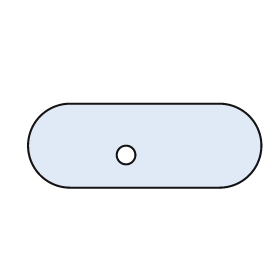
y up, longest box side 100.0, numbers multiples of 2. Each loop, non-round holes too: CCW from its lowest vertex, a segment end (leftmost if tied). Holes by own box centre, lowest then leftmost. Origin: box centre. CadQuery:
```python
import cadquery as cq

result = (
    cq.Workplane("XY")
    .moveTo(-32.0, -18.0)
    .lineTo(32.0, -18.0)
    .threePointArc((50.0, 0.0), (32.0, 18.0))
    .lineTo(-32.0, 18.0)
    .threePointArc((-50.0, 0.0), (-32.0, -18.0))
    .close()
    .moveTo(-8.0, -4.0)
    .circle(4.0)
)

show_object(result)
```